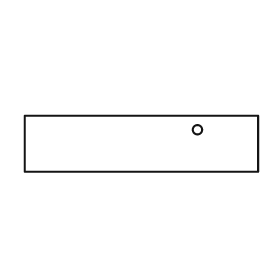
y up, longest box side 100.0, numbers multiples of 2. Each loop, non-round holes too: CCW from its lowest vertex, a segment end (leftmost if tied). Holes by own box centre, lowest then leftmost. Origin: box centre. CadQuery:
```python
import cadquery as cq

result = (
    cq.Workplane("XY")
    .moveTo(-50.0, -12.0)
    .lineTo(50.0, -12.0)
    .lineTo(50.0, 12.0)
    .lineTo(-50.0, 12.0)
    .close()
    .moveTo(24.0, 6.0)
    .circle(2.0)
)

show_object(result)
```